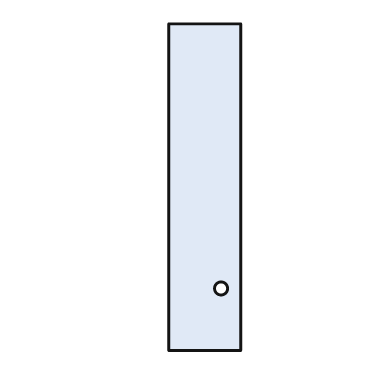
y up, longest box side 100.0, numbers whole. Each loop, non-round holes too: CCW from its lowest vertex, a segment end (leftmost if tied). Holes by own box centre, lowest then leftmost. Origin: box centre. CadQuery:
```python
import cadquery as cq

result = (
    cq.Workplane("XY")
    .moveTo(-11.0, -50.0)
    .lineTo(11.0, -50.0)
    .lineTo(11.0, 50.0)
    .lineTo(-11.0, 50.0)
    .close()
    .moveTo(5.0, -31.0)
    .circle(2.0)
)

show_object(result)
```